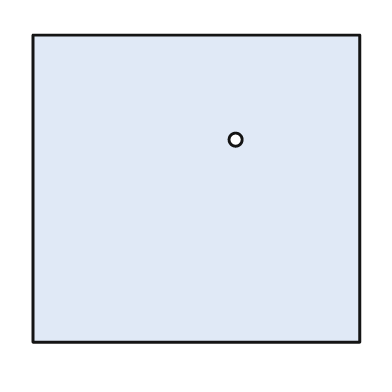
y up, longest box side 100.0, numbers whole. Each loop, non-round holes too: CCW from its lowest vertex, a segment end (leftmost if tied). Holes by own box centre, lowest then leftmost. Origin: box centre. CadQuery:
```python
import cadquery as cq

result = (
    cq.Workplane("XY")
    .moveTo(-50.0, -47.0)
    .lineTo(50.0, -47.0)
    .lineTo(50.0, 47.0)
    .lineTo(-50.0, 47.0)
    .close()
    .moveTo(12.0, 15.0)
    .circle(2.0)
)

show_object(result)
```